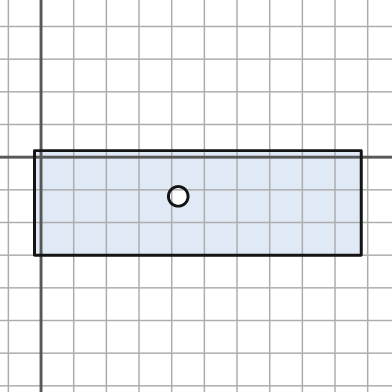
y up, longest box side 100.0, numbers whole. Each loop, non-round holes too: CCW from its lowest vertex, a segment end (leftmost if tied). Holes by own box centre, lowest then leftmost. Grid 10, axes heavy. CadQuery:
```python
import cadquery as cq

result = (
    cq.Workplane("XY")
    .moveTo(-2.0, -30.0)
    .lineTo(98.0, -30.0)
    .lineTo(98.0, 2.0)
    .lineTo(-2.0, 2.0)
    .close()
    .moveTo(42.0, -12.0)
    .circle(3.0)
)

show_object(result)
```